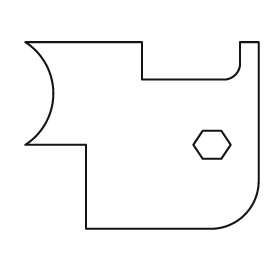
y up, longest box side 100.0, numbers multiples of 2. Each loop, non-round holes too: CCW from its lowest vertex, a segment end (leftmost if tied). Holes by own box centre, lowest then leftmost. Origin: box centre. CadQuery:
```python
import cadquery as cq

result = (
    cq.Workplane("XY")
    .moveTo(-24.0, -40.0)
    .lineTo(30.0, -40.0)
    .threePointArc((44.0, -34.0), (50.0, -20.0))
    .lineTo(50.0, 40.0)
    .lineTo(42.0, 40.0)
    .lineTo(42.0, 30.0)
    .threePointArc((40.0, 26.0), (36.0, 24.0))
    .lineTo(0.0, 24.0)
    .lineTo(0.0, 40.0)
    .lineTo(-50.0, 40.0)
    .threePointArc((-38.0, 18.0), (-50.0, -4.0))
    .lineTo(-24.0, -4.0)
    .close()
    .moveTo(26.0, -10.0)
    .lineTo(34.0, -10.0)
    .lineTo(38.0, -4.0)
    .lineTo(34.0, 2.0)
    .lineTo(26.0, 2.0)
    .lineTo(22.0, -4.0)
    .close()
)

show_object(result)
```